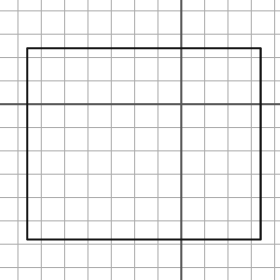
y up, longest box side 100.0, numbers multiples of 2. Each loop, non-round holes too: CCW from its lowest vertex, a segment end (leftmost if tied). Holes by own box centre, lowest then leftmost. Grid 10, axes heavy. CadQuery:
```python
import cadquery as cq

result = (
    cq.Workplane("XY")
    .moveTo(-66.0, -58.0)
    .lineTo(34.0, -58.0)
    .lineTo(34.0, 24.0)
    .lineTo(-66.0, 24.0)
    .close()
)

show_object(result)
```